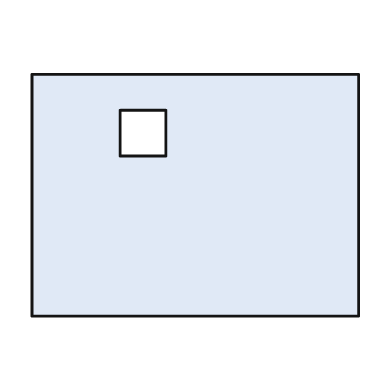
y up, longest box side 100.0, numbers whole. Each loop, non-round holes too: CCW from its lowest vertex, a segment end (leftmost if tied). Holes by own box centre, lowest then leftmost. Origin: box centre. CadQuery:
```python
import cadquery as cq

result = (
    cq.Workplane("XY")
    .moveTo(-50.0, -37.0)
    .lineTo(50.0, -37.0)
    .lineTo(50.0, 37.0)
    .lineTo(-50.0, 37.0)
    .close()
    .moveTo(-23.0, 12.0)
    .lineTo(-9.0, 12.0)
    .lineTo(-9.0, 26.0)
    .lineTo(-23.0, 26.0)
    .close()
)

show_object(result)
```